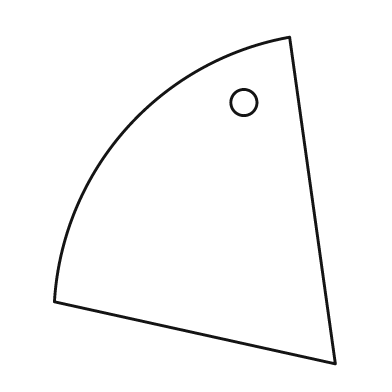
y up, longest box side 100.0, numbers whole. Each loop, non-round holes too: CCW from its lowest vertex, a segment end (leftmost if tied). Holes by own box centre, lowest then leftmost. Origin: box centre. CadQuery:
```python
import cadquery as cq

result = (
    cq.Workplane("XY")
    .moveTo(43.0, -50.0)
    .lineTo(29.0, 50.0)
    .threePointArc((-21.0, 22.0), (-43.0, -31.0))
    .close()
    .moveTo(15.0, 30.0)
    .circle(4.0)
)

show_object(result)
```